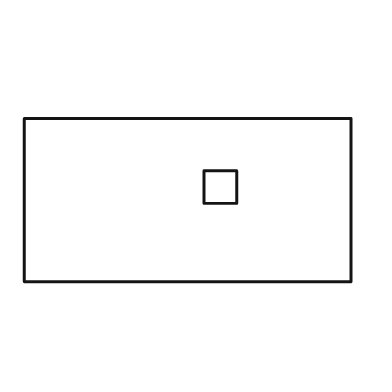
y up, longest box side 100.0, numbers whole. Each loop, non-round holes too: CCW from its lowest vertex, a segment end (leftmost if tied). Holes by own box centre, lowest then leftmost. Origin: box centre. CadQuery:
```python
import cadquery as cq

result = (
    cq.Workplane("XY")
    .moveTo(-50.0, -25.0)
    .lineTo(50.0, -25.0)
    .lineTo(50.0, 25.0)
    .lineTo(-50.0, 25.0)
    .close()
    .moveTo(5.0, -1.0)
    .lineTo(15.0, -1.0)
    .lineTo(15.0, 9.0)
    .lineTo(5.0, 9.0)
    .close()
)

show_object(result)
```